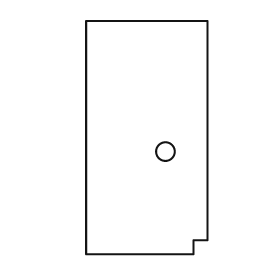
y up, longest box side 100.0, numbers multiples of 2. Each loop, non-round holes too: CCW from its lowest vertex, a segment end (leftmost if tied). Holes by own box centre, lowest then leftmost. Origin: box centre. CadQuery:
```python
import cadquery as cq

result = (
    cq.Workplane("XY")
    .moveTo(-26.0, -50.0)
    .lineTo(20.0, -50.0)
    .lineTo(20.0, -44.0)
    .lineTo(26.0, -44.0)
    .lineTo(26.0, 50.0)
    .lineTo(-26.0, 50.0)
    .close()
    .moveTo(8.0, -6.0)
    .circle(4.0)
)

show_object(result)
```